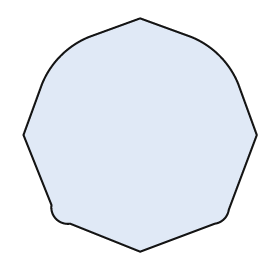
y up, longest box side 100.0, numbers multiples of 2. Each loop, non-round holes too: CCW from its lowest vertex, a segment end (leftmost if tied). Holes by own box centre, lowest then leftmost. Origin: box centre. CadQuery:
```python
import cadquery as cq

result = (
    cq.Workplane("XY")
    .moveTo(0.0, -50.0)
    .lineTo(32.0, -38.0)
    .threePointArc((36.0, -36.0), (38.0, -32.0))
    .lineTo(50.0, 0.0)
    .lineTo(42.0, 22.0)
    .threePointArc((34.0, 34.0), (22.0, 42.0))
    .lineTo(0.0, 50.0)
    .lineTo(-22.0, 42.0)
    .threePointArc((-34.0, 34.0), (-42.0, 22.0))
    .lineTo(-50.0, 0.0)
    .lineTo(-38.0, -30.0)
    .threePointArc((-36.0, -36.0), (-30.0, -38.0))
    .close()
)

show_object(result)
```